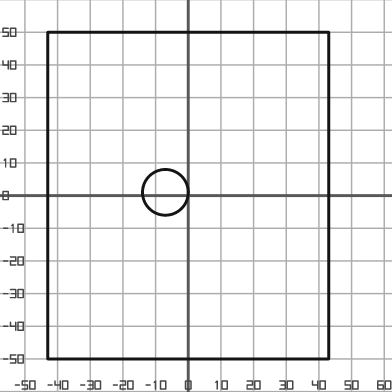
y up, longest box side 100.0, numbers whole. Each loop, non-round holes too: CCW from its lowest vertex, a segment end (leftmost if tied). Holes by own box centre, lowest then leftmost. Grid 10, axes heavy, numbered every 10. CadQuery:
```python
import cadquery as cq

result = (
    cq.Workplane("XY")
    .moveTo(-43.0, -50.0)
    .lineTo(43.0, -50.0)
    .lineTo(43.0, 50.0)
    .lineTo(-43.0, 50.0)
    .close()
    .moveTo(-7.0, 1.0)
    .circle(7.0)
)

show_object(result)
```